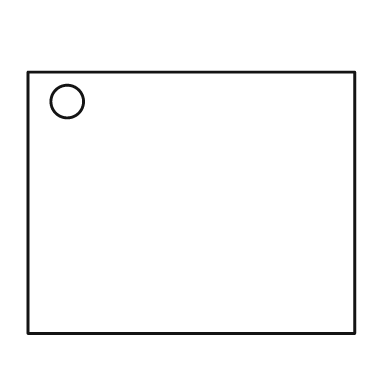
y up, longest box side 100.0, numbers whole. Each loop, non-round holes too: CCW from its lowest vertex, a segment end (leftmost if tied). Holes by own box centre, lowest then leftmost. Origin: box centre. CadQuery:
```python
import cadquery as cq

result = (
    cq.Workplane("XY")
    .moveTo(-50.0, -40.0)
    .lineTo(50.0, -40.0)
    .lineTo(50.0, 40.0)
    .lineTo(-50.0, 40.0)
    .close()
    .moveTo(-38.0, 31.0)
    .circle(5.0)
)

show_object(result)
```